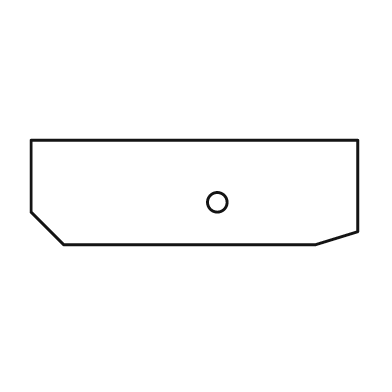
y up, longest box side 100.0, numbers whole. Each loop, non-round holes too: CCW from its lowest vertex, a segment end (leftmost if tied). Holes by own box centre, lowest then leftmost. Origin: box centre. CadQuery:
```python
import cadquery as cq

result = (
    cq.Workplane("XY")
    .moveTo(-40.0, -16.0)
    .lineTo(37.0, -16.0)
    .lineTo(50.0, -12.0)
    .lineTo(50.0, 16.0)
    .lineTo(-50.0, 16.0)
    .lineTo(-50.0, -6.0)
    .close()
    .moveTo(7.0, -3.0)
    .circle(3.0)
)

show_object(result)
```